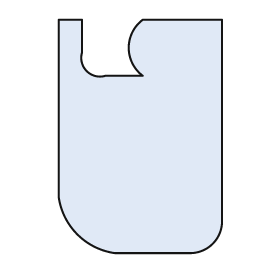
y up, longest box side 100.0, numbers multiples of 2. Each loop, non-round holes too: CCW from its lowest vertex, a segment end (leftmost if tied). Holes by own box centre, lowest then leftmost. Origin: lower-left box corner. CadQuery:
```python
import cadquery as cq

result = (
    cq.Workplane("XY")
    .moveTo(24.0, 0.0)
    .lineTo(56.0, 0.0)
    .threePointArc((66.0, 4.0), (70.0, 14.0))
    .lineTo(70.0, 100.0)
    .lineTo(36.0, 100.0)
    .threePointArc((30.0, 88.0), (36.0, 76.0))
    .lineTo(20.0, 76.0)
    .threePointArc((12.0, 78.0), (10.0, 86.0))
    .lineTo(10.0, 100.0)
    .lineTo(0.0, 100.0)
    .lineTo(0.0, 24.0)
    .threePointArc((8.0, 8.0), (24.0, 0.0))
    .close()
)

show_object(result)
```